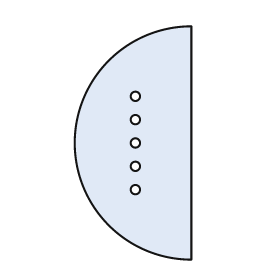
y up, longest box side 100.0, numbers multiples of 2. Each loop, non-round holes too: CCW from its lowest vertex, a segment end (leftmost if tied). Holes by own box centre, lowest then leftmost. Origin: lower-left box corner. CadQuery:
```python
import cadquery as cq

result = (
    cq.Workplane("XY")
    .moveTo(50.0, 0.0)
    .lineTo(50.0, 100.0)
    .threePointArc((0.0, 50.0), (50.0, 0.0))
    .close()
    .moveTo(26.0, 30.0)
    .circle(2.0)
    .moveTo(26.0, 40.0)
    .circle(2.0)
    .moveTo(26.0, 50.0)
    .circle(2.0)
    .moveTo(26.0, 60.0)
    .circle(2.0)
    .moveTo(26.0, 70.0)
    .circle(2.0)
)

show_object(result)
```